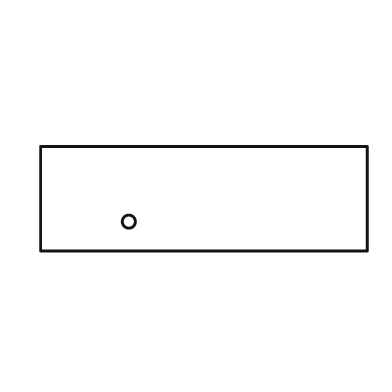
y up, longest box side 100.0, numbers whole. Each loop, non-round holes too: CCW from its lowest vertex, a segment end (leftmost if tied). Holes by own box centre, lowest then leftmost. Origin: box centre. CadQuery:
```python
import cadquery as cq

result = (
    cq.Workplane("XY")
    .moveTo(-50.0, -16.0)
    .lineTo(50.0, -16.0)
    .lineTo(50.0, 16.0)
    .lineTo(-50.0, 16.0)
    .close()
    .moveTo(-23.0, -7.0)
    .circle(2.0)
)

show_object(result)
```